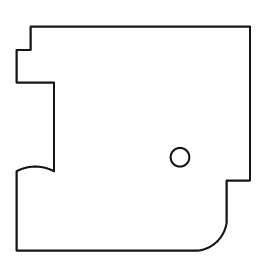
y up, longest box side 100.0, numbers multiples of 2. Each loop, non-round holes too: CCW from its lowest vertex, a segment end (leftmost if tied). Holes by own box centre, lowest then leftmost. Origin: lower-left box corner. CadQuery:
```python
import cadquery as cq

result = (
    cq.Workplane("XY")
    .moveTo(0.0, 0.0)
    .lineTo(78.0, 0.0)
    .threePointArc((86.0, 4.0), (90.0, 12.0))
    .lineTo(90.0, 30.0)
    .lineTo(100.0, 30.0)
    .lineTo(100.0, 96.0)
    .lineTo(6.0, 96.0)
    .lineTo(6.0, 86.0)
    .lineTo(0.0, 86.0)
    .lineTo(0.0, 72.0)
    .lineTo(16.0, 72.0)
    .lineTo(16.0, 34.0)
    .threePointArc((8.0, 36.0), (0.0, 34.0))
    .close()
    .moveTo(70.0, 40.0)
    .circle(4.0)
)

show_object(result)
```